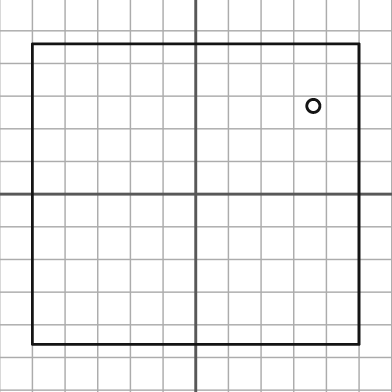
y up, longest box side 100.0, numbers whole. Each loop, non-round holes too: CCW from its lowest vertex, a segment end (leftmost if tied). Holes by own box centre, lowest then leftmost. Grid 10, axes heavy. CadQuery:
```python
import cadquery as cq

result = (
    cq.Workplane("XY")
    .moveTo(-50.0, -46.0)
    .lineTo(50.0, -46.0)
    .lineTo(50.0, 46.0)
    .lineTo(-50.0, 46.0)
    .close()
    .moveTo(36.0, 27.0)
    .circle(2.0)
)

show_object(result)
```